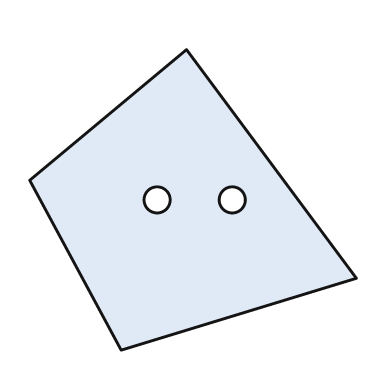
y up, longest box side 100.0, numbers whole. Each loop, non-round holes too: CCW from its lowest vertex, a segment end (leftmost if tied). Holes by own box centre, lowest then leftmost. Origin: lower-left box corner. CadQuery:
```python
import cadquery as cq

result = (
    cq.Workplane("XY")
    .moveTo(28.0, 0.0)
    .lineTo(100.0, 22.0)
    .lineTo(48.0, 92.0)
    .lineTo(0.0, 52.0)
    .close()
    .moveTo(39.0, 46.0)
    .circle(4.0)
    .moveTo(62.0, 46.0)
    .circle(4.0)
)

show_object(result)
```